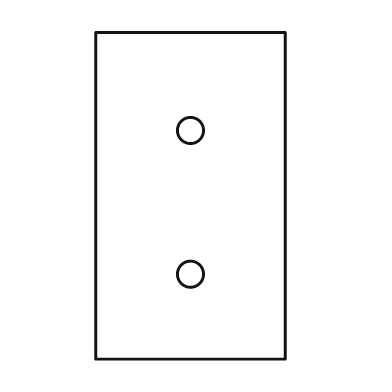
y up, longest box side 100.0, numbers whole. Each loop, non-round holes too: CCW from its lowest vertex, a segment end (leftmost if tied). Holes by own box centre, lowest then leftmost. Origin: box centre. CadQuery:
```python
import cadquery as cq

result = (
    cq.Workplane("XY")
    .moveTo(-29.0, -50.0)
    .lineTo(29.0, -50.0)
    .lineTo(29.0, 50.0)
    .lineTo(-29.0, 50.0)
    .close()
    .moveTo(0.0, -24.0)
    .circle(4.0)
    .moveTo(0.0, 20.0)
    .circle(4.0)
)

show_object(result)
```